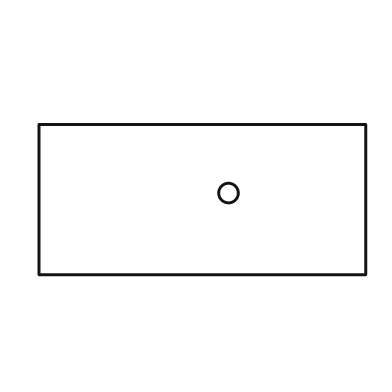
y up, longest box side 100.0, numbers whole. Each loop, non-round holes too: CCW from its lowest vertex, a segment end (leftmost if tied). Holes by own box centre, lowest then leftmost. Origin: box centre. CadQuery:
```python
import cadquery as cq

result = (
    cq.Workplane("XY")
    .moveTo(-50.0, -23.0)
    .lineTo(50.0, -23.0)
    .lineTo(50.0, 23.0)
    .lineTo(-50.0, 23.0)
    .close()
    .moveTo(8.0, 2.0)
    .circle(3.0)
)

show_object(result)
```